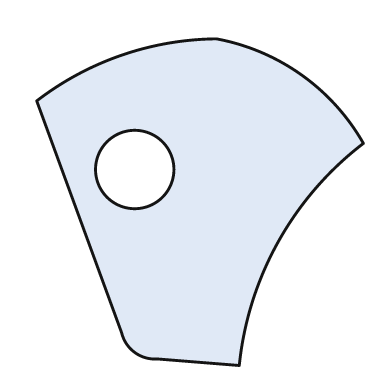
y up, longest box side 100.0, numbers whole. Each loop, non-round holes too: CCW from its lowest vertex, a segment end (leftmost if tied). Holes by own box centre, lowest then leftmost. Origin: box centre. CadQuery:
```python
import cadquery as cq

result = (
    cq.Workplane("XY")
    .moveTo(12.0, -50.0)
    .threePointArc((24.0, -12.0), (50.0, 18.0))
    .threePointArc((31.0, 39.0), (5.0, 50.0))
    .threePointArc((-24.0, 45.0), (-50.0, 31.0))
    .lineTo(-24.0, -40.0)
    .threePointArc((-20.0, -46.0), (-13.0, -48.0))
    .close()
    .moveTo(-20.0, 10.0)
    .circle(12.0)
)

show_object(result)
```